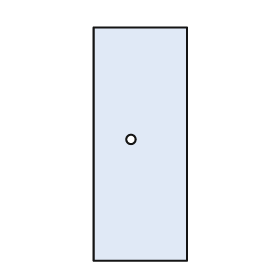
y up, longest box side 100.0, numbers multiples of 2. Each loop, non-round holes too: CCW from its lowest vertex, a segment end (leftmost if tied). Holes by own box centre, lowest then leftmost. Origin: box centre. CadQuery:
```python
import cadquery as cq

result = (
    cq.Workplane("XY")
    .moveTo(-20.0, -50.0)
    .lineTo(20.0, -50.0)
    .lineTo(20.0, 50.0)
    .lineTo(-20.0, 50.0)
    .close()
    .moveTo(-4.0, 2.0)
    .circle(2.0)
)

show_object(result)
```